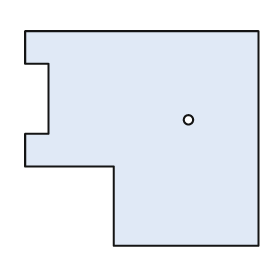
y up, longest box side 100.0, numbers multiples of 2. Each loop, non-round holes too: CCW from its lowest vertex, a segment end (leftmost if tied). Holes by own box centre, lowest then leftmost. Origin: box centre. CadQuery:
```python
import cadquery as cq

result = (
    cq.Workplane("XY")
    .moveTo(-12.0, -46.0)
    .lineTo(50.0, -46.0)
    .lineTo(50.0, 46.0)
    .lineTo(-50.0, 46.0)
    .lineTo(-50.0, 32.0)
    .lineTo(-40.0, 32.0)
    .lineTo(-40.0, 2.0)
    .lineTo(-50.0, 2.0)
    .lineTo(-50.0, -12.0)
    .lineTo(-12.0, -12.0)
    .close()
    .moveTo(20.0, 8.0)
    .circle(2.0)
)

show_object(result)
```